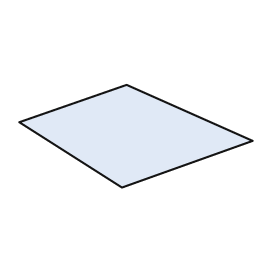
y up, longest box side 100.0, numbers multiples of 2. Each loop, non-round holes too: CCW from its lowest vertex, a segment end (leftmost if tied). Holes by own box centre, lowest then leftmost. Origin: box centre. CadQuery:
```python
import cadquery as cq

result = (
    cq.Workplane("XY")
    .moveTo(-6.0, -22.0)
    .lineTo(50.0, -2.0)
    .lineTo(-4.0, 22.0)
    .lineTo(-50.0, 6.0)
    .close()
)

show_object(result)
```